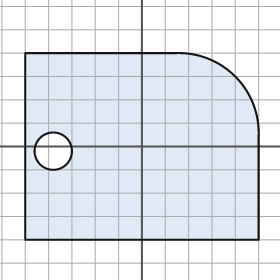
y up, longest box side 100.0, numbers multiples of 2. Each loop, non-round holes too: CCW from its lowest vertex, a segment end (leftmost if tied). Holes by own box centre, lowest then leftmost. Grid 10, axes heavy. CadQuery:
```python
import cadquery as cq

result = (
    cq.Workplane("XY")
    .moveTo(-50.0, -40.0)
    .lineTo(50.0, -40.0)
    .lineTo(50.0, 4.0)
    .threePointArc((40.0, 30.0), (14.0, 40.0))
    .lineTo(-50.0, 40.0)
    .close()
    .moveTo(-38.0, -2.0)
    .circle(8.0)
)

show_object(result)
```